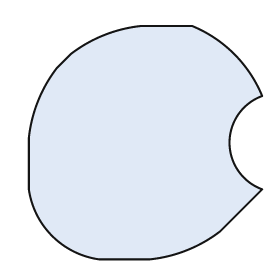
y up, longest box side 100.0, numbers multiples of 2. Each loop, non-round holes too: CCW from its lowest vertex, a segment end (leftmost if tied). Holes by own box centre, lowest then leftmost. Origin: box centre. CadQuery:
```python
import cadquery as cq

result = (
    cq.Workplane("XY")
    .moveTo(-20.0, -50.0)
    .lineTo(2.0, -50.0)
    .threePointArc((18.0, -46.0), (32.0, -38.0))
    .lineTo(50.0, -20.0)
    .threePointArc((36.0, 0.0), (50.0, 20.0))
    .threePointArc((38.0, 38.0), (20.0, 50.0))
    .lineTo(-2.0, 50.0)
    .threePointArc((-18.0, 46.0), (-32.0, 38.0))
    .lineTo(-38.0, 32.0)
    .threePointArc((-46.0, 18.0), (-50.0, 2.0))
    .lineTo(-50.0, -20.0)
    .threePointArc((-40.0, -40.0), (-20.0, -50.0))
    .close()
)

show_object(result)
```